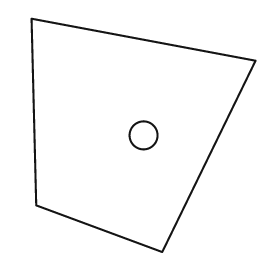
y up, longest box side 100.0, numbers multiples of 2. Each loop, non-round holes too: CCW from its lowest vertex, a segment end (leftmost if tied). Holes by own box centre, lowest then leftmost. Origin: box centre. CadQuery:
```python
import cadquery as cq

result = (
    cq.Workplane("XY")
    .moveTo(8.0, -50.0)
    .lineTo(48.0, 32.0)
    .lineTo(-48.0, 50.0)
    .lineTo(-46.0, -30.0)
    .close()
    .moveTo(0.0, 0.0)
    .circle(6.0)
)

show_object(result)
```